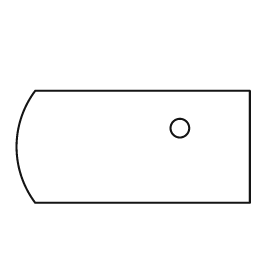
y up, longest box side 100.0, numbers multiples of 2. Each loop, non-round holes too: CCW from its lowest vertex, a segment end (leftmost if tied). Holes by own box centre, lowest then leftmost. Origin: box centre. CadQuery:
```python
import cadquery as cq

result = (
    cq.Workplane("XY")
    .moveTo(-42.0, -24.0)
    .lineTo(50.0, -24.0)
    .lineTo(50.0, 24.0)
    .lineTo(-42.0, 24.0)
    .threePointArc((-50.0, 0.0), (-42.0, -24.0))
    .close()
    .moveTo(20.0, 8.0)
    .circle(4.0)
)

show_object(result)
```